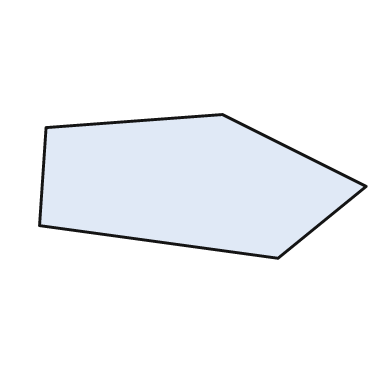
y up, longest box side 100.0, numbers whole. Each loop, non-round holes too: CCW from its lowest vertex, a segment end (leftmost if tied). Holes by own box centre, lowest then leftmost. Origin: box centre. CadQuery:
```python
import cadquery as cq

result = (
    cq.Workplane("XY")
    .moveTo(23.0, -22.0)
    .lineTo(50.0, 0.0)
    .lineTo(6.0, 22.0)
    .lineTo(-48.0, 18.0)
    .lineTo(-50.0, -12.0)
    .close()
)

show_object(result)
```